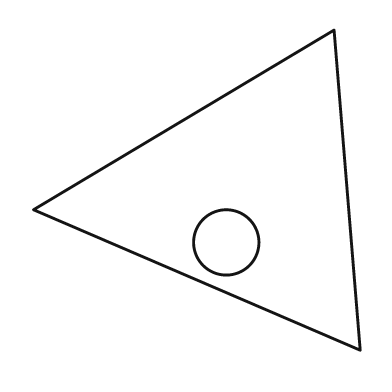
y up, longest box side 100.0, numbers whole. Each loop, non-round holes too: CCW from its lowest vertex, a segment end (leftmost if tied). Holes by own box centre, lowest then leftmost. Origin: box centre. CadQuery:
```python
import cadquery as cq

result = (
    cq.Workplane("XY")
    .moveTo(50.0, -49.0)
    .lineTo(42.0, 49.0)
    .lineTo(-50.0, -6.0)
    .close()
    .moveTo(9.0, -16.0)
    .circle(10.0)
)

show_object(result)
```